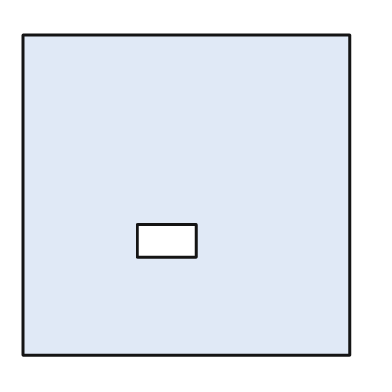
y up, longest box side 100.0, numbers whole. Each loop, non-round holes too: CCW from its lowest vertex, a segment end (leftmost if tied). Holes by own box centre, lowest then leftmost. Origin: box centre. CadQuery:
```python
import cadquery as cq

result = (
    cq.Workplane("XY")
    .moveTo(-50.0, -49.0)
    .lineTo(50.0, -49.0)
    .lineTo(50.0, 49.0)
    .lineTo(-50.0, 49.0)
    .close()
    .moveTo(-15.0, -19.0)
    .lineTo(3.0, -19.0)
    .lineTo(3.0, -9.0)
    .lineTo(-15.0, -9.0)
    .close()
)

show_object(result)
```